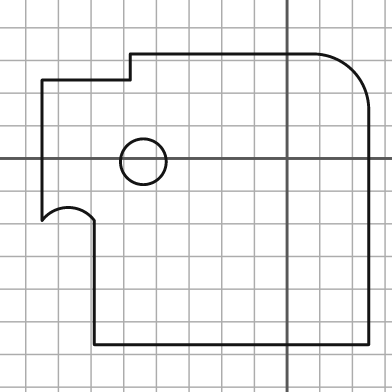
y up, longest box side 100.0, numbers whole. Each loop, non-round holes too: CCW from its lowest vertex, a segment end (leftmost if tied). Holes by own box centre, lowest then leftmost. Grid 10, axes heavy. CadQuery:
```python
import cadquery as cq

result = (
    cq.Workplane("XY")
    .moveTo(-59.0, -57.0)
    .lineTo(25.0, -57.0)
    .lineTo(25.0, 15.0)
    .threePointArc((20.0, 27.0), (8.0, 32.0))
    .lineTo(-48.0, 32.0)
    .lineTo(-48.0, 24.0)
    .lineTo(-75.0, 24.0)
    .lineTo(-75.0, -19.0)
    .threePointArc((-67.0, -15.0), (-59.0, -19.0))
    .close()
    .moveTo(-44.0, -1.0)
    .circle(7.0)
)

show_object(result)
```